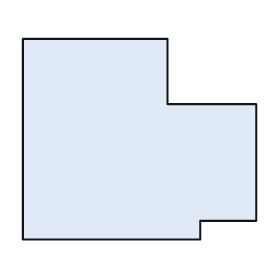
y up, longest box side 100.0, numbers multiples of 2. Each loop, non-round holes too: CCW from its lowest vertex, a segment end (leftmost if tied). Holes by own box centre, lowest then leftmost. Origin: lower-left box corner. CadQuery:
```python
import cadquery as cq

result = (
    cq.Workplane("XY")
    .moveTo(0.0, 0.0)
    .lineTo(76.0, 0.0)
    .lineTo(76.0, 8.0)
    .lineTo(100.0, 8.0)
    .lineTo(100.0, 58.0)
    .lineTo(62.0, 58.0)
    .lineTo(62.0, 86.0)
    .lineTo(0.0, 86.0)
    .close()
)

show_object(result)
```